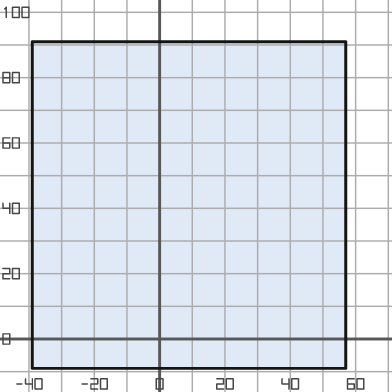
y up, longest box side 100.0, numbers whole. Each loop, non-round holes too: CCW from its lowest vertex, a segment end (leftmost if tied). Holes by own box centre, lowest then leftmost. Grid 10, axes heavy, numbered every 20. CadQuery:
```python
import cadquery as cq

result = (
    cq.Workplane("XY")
    .moveTo(-39.0, -9.0)
    .lineTo(57.0, -9.0)
    .lineTo(57.0, 91.0)
    .lineTo(-39.0, 91.0)
    .close()
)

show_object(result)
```